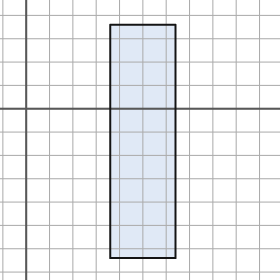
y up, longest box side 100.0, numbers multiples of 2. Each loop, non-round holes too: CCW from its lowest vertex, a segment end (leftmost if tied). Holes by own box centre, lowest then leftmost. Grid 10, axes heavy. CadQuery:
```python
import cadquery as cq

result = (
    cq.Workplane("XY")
    .moveTo(36.0, -64.0)
    .lineTo(64.0, -64.0)
    .lineTo(64.0, 36.0)
    .lineTo(36.0, 36.0)
    .close()
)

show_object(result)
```